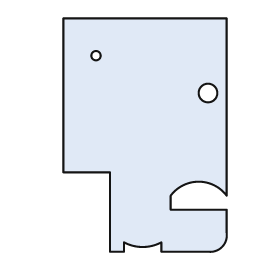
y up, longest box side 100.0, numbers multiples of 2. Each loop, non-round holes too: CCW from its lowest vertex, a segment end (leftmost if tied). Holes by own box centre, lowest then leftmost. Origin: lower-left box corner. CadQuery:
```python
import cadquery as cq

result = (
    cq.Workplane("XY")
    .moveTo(20.0, 0.0)
    .lineTo(26.0, 0.0)
    .lineTo(26.0, 4.0)
    .threePointArc((34.0, 2.0), (42.0, 4.0))
    .lineTo(42.0, 0.0)
    .lineTo(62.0, 0.0)
    .threePointArc((68.0, 2.0), (70.0, 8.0))
    .lineTo(70.0, 18.0)
    .lineTo(46.0, 18.0)
    .lineTo(46.0, 24.0)
    .threePointArc((58.0, 30.0), (70.0, 24.0))
    .lineTo(70.0, 100.0)
    .lineTo(0.0, 100.0)
    .lineTo(0.0, 34.0)
    .lineTo(20.0, 34.0)
    .close()
    .moveTo(62.0, 68.0)
    .circle(4.0)
    .moveTo(14.0, 84.0)
    .circle(2.0)
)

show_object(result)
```